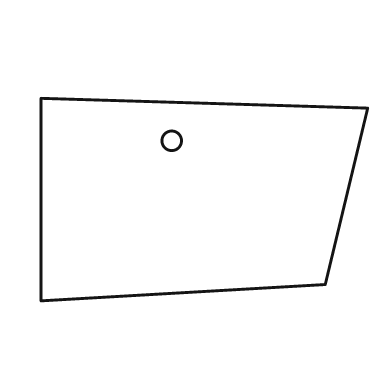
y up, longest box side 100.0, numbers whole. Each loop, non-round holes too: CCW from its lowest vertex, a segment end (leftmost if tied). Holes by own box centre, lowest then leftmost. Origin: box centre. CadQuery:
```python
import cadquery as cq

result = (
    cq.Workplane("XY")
    .moveTo(-50.0, -31.0)
    .lineTo(37.0, -26.0)
    .lineTo(50.0, 28.0)
    .lineTo(-50.0, 31.0)
    .close()
    .moveTo(-10.0, 18.0)
    .circle(3.0)
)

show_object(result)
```